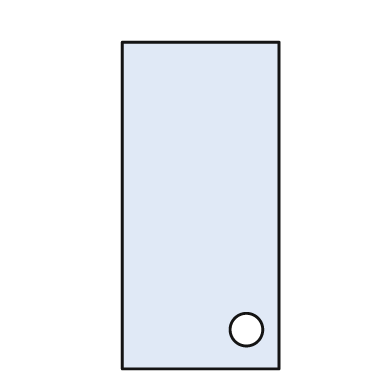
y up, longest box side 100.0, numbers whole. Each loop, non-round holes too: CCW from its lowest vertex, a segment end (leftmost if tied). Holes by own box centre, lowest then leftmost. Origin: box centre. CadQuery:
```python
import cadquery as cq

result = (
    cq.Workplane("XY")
    .moveTo(-24.0, -50.0)
    .lineTo(24.0, -50.0)
    .lineTo(24.0, 50.0)
    .lineTo(-24.0, 50.0)
    .close()
    .moveTo(14.0, -38.0)
    .circle(5.0)
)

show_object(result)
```